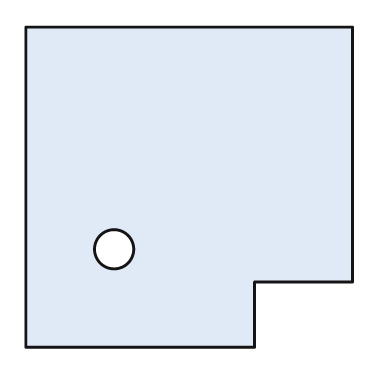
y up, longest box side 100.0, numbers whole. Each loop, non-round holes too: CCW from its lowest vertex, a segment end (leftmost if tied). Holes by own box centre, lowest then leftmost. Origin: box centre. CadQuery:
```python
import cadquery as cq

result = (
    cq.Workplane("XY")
    .moveTo(-50.0, -49.0)
    .lineTo(20.0, -49.0)
    .lineTo(20.0, -29.0)
    .lineTo(50.0, -29.0)
    .lineTo(50.0, 49.0)
    .lineTo(-50.0, 49.0)
    .close()
    .moveTo(-23.0, -19.0)
    .circle(6.0)
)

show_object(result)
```